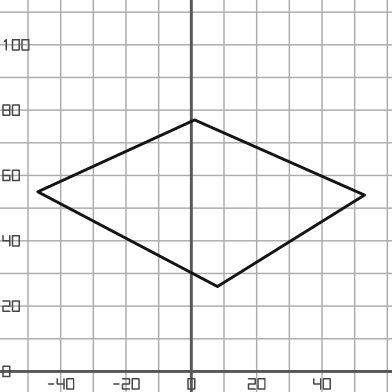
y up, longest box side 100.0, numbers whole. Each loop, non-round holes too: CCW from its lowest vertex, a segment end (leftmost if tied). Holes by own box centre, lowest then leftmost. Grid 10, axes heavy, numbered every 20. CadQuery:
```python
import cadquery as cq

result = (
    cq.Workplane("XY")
    .moveTo(8.0, 26.0)
    .lineTo(53.0, 54.0)
    .lineTo(1.0, 77.0)
    .lineTo(-47.0, 55.0)
    .close()
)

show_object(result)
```